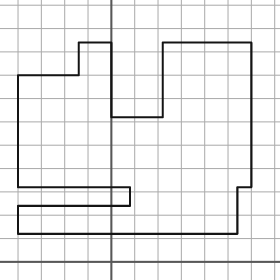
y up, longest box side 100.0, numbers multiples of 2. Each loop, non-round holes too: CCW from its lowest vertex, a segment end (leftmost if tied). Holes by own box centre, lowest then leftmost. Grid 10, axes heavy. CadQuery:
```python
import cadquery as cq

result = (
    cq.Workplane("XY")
    .moveTo(-40.0, 12.0)
    .lineTo(54.0, 12.0)
    .lineTo(54.0, 32.0)
    .lineTo(60.0, 32.0)
    .lineTo(60.0, 94.0)
    .lineTo(22.0, 94.0)
    .lineTo(22.0, 62.0)
    .lineTo(0.0, 62.0)
    .lineTo(0.0, 94.0)
    .lineTo(-14.0, 94.0)
    .lineTo(-14.0, 80.0)
    .lineTo(-40.0, 80.0)
    .lineTo(-40.0, 32.0)
    .lineTo(8.0, 32.0)
    .lineTo(8.0, 24.0)
    .lineTo(-40.0, 24.0)
    .close()
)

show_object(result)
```